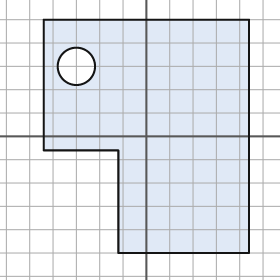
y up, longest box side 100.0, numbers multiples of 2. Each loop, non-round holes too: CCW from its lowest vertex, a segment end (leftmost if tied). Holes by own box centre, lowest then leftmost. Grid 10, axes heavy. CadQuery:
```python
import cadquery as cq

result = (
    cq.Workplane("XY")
    .moveTo(-12.0, -50.0)
    .lineTo(44.0, -50.0)
    .lineTo(44.0, 50.0)
    .lineTo(-44.0, 50.0)
    .lineTo(-44.0, -6.0)
    .lineTo(-12.0, -6.0)
    .close()
    .moveTo(-30.0, 30.0)
    .circle(8.0)
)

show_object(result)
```